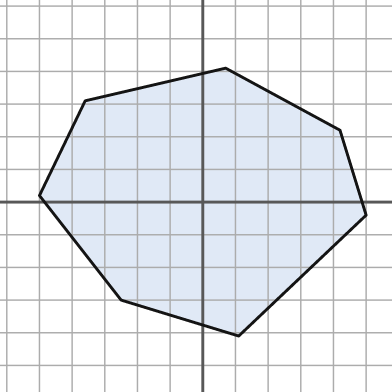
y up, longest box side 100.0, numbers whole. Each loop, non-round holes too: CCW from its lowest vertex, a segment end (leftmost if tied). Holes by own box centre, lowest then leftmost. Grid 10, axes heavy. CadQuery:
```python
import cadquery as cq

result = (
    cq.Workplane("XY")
    .moveTo(11.0, -41.0)
    .lineTo(50.0, -4.0)
    .lineTo(42.0, 22.0)
    .lineTo(7.0, 41.0)
    .lineTo(-36.0, 31.0)
    .lineTo(-50.0, 2.0)
    .lineTo(-25.0, -30.0)
    .close()
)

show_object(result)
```